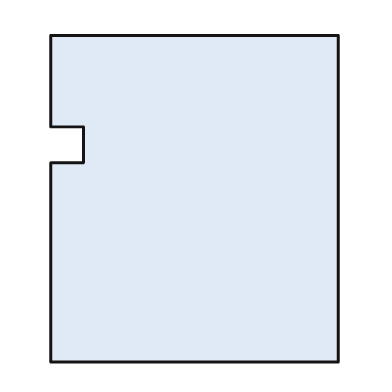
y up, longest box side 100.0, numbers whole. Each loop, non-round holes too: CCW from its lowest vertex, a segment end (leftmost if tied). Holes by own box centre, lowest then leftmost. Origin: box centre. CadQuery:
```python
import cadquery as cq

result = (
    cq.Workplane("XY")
    .moveTo(-44.0, -50.0)
    .lineTo(44.0, -50.0)
    .lineTo(44.0, 50.0)
    .lineTo(-44.0, 50.0)
    .lineTo(-44.0, 22.0)
    .lineTo(-34.0, 22.0)
    .lineTo(-34.0, 11.0)
    .lineTo(-44.0, 11.0)
    .close()
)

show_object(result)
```